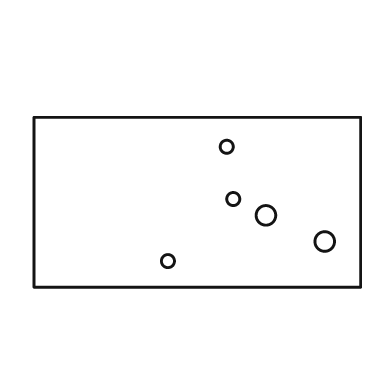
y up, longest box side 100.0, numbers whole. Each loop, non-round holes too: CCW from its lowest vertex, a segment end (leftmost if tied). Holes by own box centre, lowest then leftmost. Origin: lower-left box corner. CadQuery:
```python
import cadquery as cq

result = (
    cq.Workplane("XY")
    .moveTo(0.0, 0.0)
    .lineTo(100.0, 0.0)
    .lineTo(100.0, 52.0)
    .lineTo(0.0, 52.0)
    .close()
    .moveTo(41.0, 8.0)
    .circle(2.0)
    .moveTo(89.0, 14.0)
    .circle(3.0)
    .moveTo(71.0, 22.0)
    .circle(3.0)
    .moveTo(61.0, 27.0)
    .circle(2.0)
    .moveTo(59.0, 43.0)
    .circle(2.0)
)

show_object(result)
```